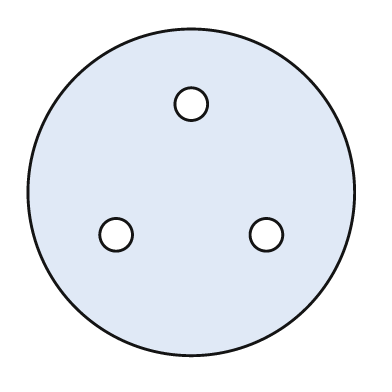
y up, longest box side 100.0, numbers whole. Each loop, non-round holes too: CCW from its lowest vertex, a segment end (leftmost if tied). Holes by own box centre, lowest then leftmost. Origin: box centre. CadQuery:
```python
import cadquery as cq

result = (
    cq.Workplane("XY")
    .moveTo(0.0, 0.0)
    .circle(50.0)
    .moveTo(-23.0, -13.0)
    .circle(5.0)
    .moveTo(23.0, -13.0)
    .circle(5.0)
    .moveTo(0.0, 27.0)
    .circle(5.0)
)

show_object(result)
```